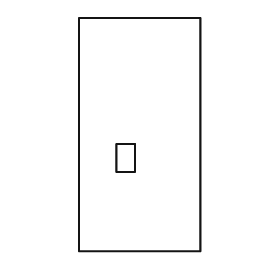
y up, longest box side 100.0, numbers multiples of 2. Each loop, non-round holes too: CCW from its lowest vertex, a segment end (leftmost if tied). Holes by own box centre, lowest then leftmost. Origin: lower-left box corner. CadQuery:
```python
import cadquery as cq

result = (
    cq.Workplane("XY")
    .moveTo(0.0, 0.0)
    .lineTo(52.0, 0.0)
    .lineTo(52.0, 100.0)
    .lineTo(0.0, 100.0)
    .close()
    .moveTo(16.0, 34.0)
    .lineTo(24.0, 34.0)
    .lineTo(24.0, 46.0)
    .lineTo(16.0, 46.0)
    .close()
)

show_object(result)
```